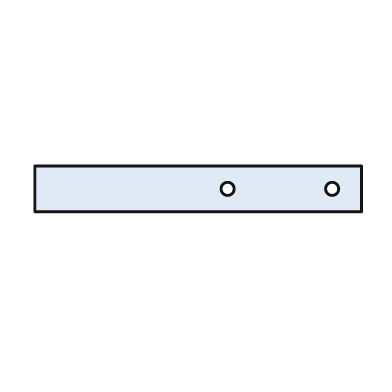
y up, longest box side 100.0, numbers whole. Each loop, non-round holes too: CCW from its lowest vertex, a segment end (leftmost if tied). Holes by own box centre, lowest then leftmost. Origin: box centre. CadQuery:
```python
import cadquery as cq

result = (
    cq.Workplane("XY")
    .moveTo(-50.0, -7.0)
    .lineTo(50.0, -7.0)
    .lineTo(50.0, 7.0)
    .lineTo(-50.0, 7.0)
    .close()
    .moveTo(9.0, 0.0)
    .circle(2.0)
    .moveTo(41.0, 0.0)
    .circle(2.0)
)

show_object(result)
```